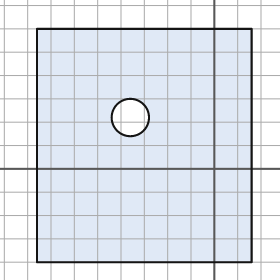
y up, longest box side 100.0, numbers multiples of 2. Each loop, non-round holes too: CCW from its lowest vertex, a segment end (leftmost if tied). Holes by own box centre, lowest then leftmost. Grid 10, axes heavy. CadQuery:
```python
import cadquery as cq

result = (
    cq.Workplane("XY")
    .moveTo(-76.0, -40.0)
    .lineTo(16.0, -40.0)
    .lineTo(16.0, 60.0)
    .lineTo(-76.0, 60.0)
    .close()
    .moveTo(-36.0, 22.0)
    .circle(8.0)
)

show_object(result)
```